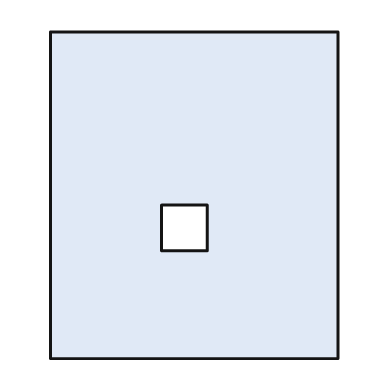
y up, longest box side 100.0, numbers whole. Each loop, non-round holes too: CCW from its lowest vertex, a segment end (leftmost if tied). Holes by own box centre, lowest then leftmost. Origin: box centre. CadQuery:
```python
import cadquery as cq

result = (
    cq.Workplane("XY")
    .moveTo(-44.0, -50.0)
    .lineTo(44.0, -50.0)
    .lineTo(44.0, 50.0)
    .lineTo(-44.0, 50.0)
    .close()
    .moveTo(-10.0, -17.0)
    .lineTo(4.0, -17.0)
    .lineTo(4.0, -3.0)
    .lineTo(-10.0, -3.0)
    .close()
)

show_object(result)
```